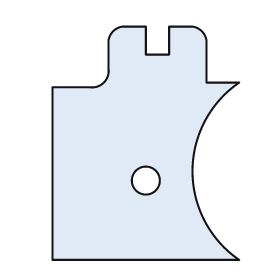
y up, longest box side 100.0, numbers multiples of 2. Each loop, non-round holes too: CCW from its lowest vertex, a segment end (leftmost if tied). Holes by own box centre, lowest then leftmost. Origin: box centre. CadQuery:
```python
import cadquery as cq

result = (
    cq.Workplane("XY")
    .moveTo(-40.0, -50.0)
    .lineTo(40.0, -50.0)
    .threePointArc((20.0, -12.0), (40.0, 26.0))
    .lineTo(26.0, 26.0)
    .lineTo(26.0, 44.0)
    .threePointArc((24.0, 48.0), (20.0, 50.0))
    .lineTo(10.0, 50.0)
    .lineTo(10.0, 38.0)
    .lineTo(0.0, 38.0)
    .lineTo(0.0, 50.0)
    .lineTo(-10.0, 50.0)
    .threePointArc((-14.0, 48.0), (-16.0, 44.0))
    .lineTo(-16.0, 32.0)
    .threePointArc((-18.0, 26.0), (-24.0, 24.0))
    .lineTo(-40.0, 24.0)
    .close()
    .moveTo(0.0, -16.0)
    .circle(6.0)
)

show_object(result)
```